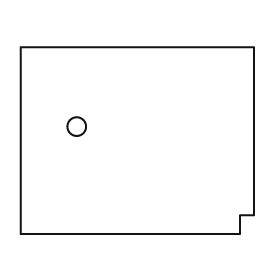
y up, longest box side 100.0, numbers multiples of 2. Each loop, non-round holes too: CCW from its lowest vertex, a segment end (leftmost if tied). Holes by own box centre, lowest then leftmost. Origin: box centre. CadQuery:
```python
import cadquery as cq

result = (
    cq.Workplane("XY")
    .moveTo(-50.0, -40.0)
    .lineTo(44.0, -40.0)
    .lineTo(44.0, -32.0)
    .lineTo(50.0, -32.0)
    .lineTo(50.0, 40.0)
    .lineTo(-50.0, 40.0)
    .close()
    .moveTo(-26.0, 6.0)
    .circle(4.0)
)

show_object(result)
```